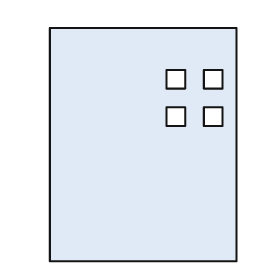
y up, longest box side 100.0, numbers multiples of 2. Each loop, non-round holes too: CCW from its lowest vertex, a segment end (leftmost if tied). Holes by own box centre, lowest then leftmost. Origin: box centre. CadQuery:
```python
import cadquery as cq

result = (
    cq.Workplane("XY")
    .moveTo(-40.0, -50.0)
    .lineTo(40.0, -50.0)
    .lineTo(40.0, 50.0)
    .lineTo(-40.0, 50.0)
    .close()
    .moveTo(10.0, 8.0)
    .lineTo(18.0, 8.0)
    .lineTo(18.0, 16.0)
    .lineTo(10.0, 16.0)
    .close()
    .moveTo(26.0, 8.0)
    .lineTo(34.0, 8.0)
    .lineTo(34.0, 16.0)
    .lineTo(26.0, 16.0)
    .close()
    .moveTo(10.0, 24.0)
    .lineTo(18.0, 24.0)
    .lineTo(18.0, 32.0)
    .lineTo(10.0, 32.0)
    .close()
    .moveTo(26.0, 24.0)
    .lineTo(34.0, 24.0)
    .lineTo(34.0, 32.0)
    .lineTo(26.0, 32.0)
    .close()
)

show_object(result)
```